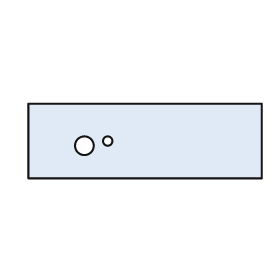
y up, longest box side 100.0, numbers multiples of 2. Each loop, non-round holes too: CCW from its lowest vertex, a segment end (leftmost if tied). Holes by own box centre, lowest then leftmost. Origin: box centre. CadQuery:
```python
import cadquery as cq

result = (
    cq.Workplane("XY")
    .moveTo(-50.0, -16.0)
    .lineTo(50.0, -16.0)
    .lineTo(50.0, 16.0)
    .lineTo(-50.0, 16.0)
    .close()
    .moveTo(-26.0, -2.0)
    .circle(4.0)
    .moveTo(-16.0, 0.0)
    .circle(2.0)
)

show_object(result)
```